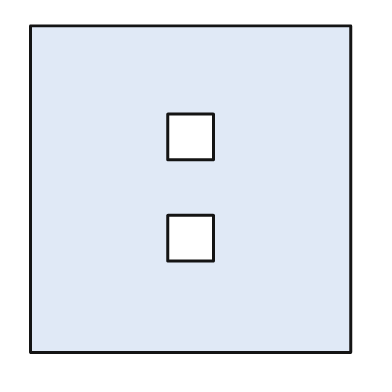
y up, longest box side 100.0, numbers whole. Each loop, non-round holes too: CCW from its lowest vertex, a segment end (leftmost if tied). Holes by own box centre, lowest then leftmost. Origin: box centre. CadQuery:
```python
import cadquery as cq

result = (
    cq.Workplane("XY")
    .moveTo(-49.0, -50.0)
    .lineTo(49.0, -50.0)
    .lineTo(49.0, 50.0)
    .lineTo(-49.0, 50.0)
    .close()
    .moveTo(-7.0, -22.0)
    .lineTo(7.0, -22.0)
    .lineTo(7.0, -8.0)
    .lineTo(-7.0, -8.0)
    .close()
    .moveTo(-7.0, 9.0)
    .lineTo(7.0, 9.0)
    .lineTo(7.0, 23.0)
    .lineTo(-7.0, 23.0)
    .close()
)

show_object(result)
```